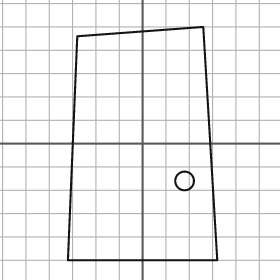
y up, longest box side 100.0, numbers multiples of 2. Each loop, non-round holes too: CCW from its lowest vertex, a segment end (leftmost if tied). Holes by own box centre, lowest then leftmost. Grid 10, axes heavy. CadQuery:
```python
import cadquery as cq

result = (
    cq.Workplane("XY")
    .moveTo(-32.0, -50.0)
    .lineTo(32.0, -50.0)
    .lineTo(26.0, 50.0)
    .lineTo(-28.0, 46.0)
    .close()
    .moveTo(18.0, -16.0)
    .circle(4.0)
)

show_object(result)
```